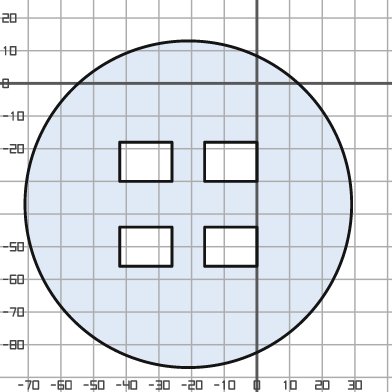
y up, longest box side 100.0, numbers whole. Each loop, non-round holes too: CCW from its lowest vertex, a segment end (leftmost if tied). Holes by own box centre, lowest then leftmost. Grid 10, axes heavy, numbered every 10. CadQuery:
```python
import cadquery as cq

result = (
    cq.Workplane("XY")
    .moveTo(-21.0, -37.0)
    .circle(50.0)
    .moveTo(-42.0, -56.0)
    .lineTo(-26.0, -56.0)
    .lineTo(-26.0, -44.0)
    .lineTo(-42.0, -44.0)
    .close()
    .moveTo(-16.0, -56.0)
    .lineTo(0.0, -56.0)
    .lineTo(0.0, -44.0)
    .lineTo(-16.0, -44.0)
    .close()
    .moveTo(-42.0, -30.0)
    .lineTo(-26.0, -30.0)
    .lineTo(-26.0, -18.0)
    .lineTo(-42.0, -18.0)
    .close()
    .moveTo(-16.0, -30.0)
    .lineTo(0.0, -30.0)
    .lineTo(0.0, -18.0)
    .lineTo(-16.0, -18.0)
    .close()
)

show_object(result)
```